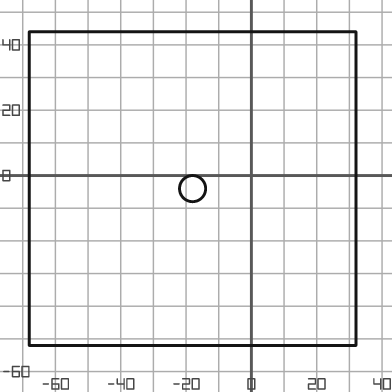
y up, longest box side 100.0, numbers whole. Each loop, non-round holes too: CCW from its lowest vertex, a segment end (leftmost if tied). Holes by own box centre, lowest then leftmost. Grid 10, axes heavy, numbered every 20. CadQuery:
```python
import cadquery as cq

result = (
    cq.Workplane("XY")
    .moveTo(-68.0, -52.0)
    .lineTo(32.0, -52.0)
    .lineTo(32.0, 44.0)
    .lineTo(-68.0, 44.0)
    .close()
    .moveTo(-18.0, -4.0)
    .circle(4.0)
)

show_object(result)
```